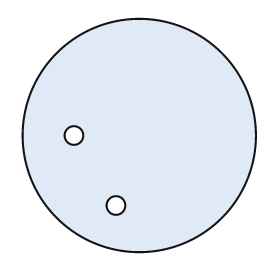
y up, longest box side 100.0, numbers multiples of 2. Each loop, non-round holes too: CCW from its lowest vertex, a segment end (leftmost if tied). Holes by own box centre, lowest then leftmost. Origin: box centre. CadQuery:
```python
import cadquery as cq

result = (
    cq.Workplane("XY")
    .moveTo(0.0, 0.0)
    .circle(50.0)
    .moveTo(-10.0, -30.0)
    .circle(4.0)
    .moveTo(-28.0, 0.0)
    .circle(4.0)
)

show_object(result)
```